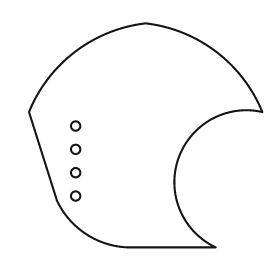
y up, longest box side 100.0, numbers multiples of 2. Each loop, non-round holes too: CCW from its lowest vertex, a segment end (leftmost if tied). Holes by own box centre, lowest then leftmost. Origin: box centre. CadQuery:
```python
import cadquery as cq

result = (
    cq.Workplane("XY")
    .moveTo(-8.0, -48.0)
    .lineTo(30.0, -48.0)
    .threePointArc((14.0, -10.0), (50.0, 10.0))
    .threePointArc((30.0, 36.0), (0.0, 48.0))
    .threePointArc((-30.0, 36.0), (-50.0, 10.0))
    .lineTo(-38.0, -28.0)
    .threePointArc((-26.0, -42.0), (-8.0, -48.0))
    .close()
    .moveTo(-30.0, -26.0)
    .circle(2.0)
    .moveTo(-30.0, -16.0)
    .circle(2.0)
    .moveTo(-30.0, -6.0)
    .circle(2.0)
    .moveTo(-30.0, 4.0)
    .circle(2.0)
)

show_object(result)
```